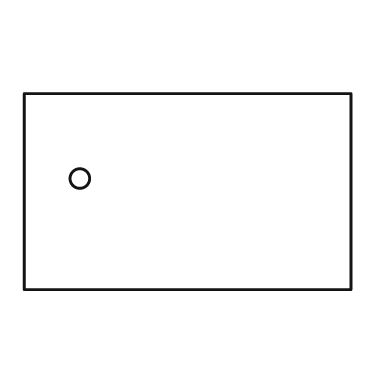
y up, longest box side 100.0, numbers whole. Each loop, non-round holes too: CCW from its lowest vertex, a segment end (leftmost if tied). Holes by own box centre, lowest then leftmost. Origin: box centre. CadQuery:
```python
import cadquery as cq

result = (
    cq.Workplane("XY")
    .moveTo(-50.0, -30.0)
    .lineTo(50.0, -30.0)
    .lineTo(50.0, 30.0)
    .lineTo(-50.0, 30.0)
    .close()
    .moveTo(-33.0, 4.0)
    .circle(3.0)
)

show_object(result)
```